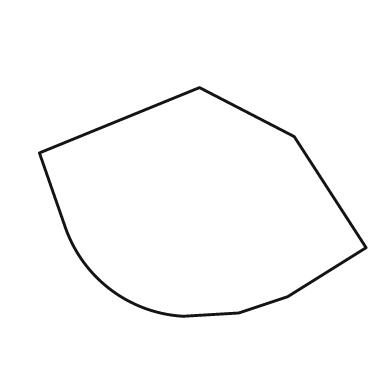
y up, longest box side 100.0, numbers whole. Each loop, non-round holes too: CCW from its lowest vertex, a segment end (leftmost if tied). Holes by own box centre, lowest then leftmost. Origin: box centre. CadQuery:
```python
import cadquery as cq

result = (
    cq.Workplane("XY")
    .moveTo(-6.0, -35.0)
    .lineTo(11.0, -34.0)
    .lineTo(26.0, -29.0)
    .lineTo(50.0, -14.0)
    .lineTo(28.0, 20.0)
    .lineTo(-1.0, 35.0)
    .lineTo(-50.0, 15.0)
    .lineTo(-42.0, -8.0)
    .threePointArc((-28.0, -27.0), (-6.0, -35.0))
    .close()
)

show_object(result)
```